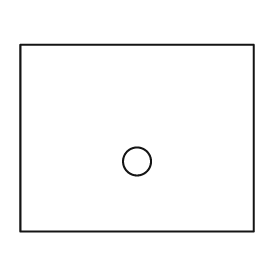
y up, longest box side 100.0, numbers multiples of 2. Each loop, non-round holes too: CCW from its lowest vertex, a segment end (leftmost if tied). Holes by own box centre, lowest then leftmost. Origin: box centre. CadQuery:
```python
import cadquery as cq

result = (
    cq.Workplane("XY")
    .moveTo(-50.0, -40.0)
    .lineTo(50.0, -40.0)
    .lineTo(50.0, 40.0)
    .lineTo(-50.0, 40.0)
    .close()
    .moveTo(0.0, -10.0)
    .circle(6.0)
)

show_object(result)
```